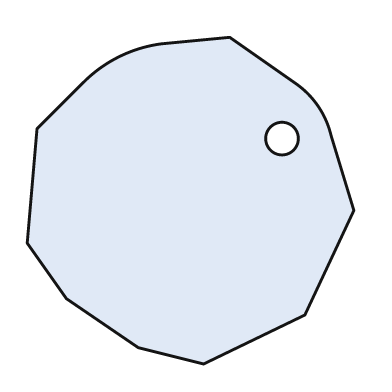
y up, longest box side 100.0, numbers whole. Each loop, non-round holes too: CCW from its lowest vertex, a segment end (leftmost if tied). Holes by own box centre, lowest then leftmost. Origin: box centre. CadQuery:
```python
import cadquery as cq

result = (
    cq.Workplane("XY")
    .moveTo(4.0, -50.0)
    .lineTo(35.0, -35.0)
    .lineTo(50.0, -3.0)
    .lineTo(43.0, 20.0)
    .threePointArc((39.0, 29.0), (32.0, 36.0))
    .lineTo(12.0, 50.0)
    .lineTo(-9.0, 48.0)
    .threePointArc((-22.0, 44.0), (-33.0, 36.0))
    .lineTo(-47.0, 22.0)
    .lineTo(-50.0, -13.0)
    .lineTo(-38.0, -30.0)
    .lineTo(-16.0, -45.0)
    .close()
    .moveTo(28.0, 19.0)
    .circle(5.0)
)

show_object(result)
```